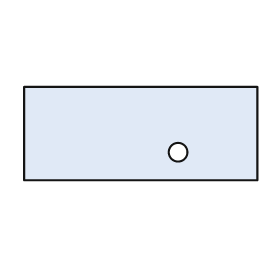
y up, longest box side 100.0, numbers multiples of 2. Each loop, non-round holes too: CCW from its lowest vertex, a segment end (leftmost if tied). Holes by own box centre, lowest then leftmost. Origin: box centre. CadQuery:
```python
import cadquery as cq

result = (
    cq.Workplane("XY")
    .moveTo(-50.0, -20.0)
    .lineTo(50.0, -20.0)
    .lineTo(50.0, 20.0)
    .lineTo(-50.0, 20.0)
    .close()
    .moveTo(16.0, -8.0)
    .circle(4.0)
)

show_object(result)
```